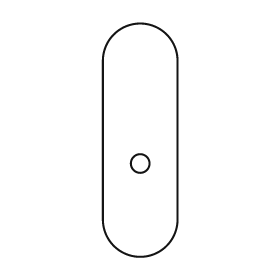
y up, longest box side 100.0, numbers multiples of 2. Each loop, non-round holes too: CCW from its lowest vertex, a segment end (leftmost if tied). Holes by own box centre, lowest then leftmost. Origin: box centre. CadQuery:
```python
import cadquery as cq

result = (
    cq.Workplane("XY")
    .moveTo(-16.0, -34.0)
    .threePointArc((0.0, -50.0), (16.0, -34.0))
    .lineTo(16.0, 34.0)
    .threePointArc((0.0, 50.0), (-16.0, 34.0))
    .close()
    .moveTo(0.0, -10.0)
    .circle(4.0)
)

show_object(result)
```